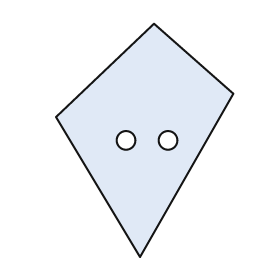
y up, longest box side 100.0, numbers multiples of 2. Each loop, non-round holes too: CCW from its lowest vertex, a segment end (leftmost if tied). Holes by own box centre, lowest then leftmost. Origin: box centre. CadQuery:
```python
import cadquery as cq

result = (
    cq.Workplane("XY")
    .moveTo(-2.0, -50.0)
    .lineTo(38.0, 20.0)
    .lineTo(4.0, 50.0)
    .lineTo(-38.0, 10.0)
    .close()
    .moveTo(-8.0, 0.0)
    .circle(4.0)
    .moveTo(10.0, 0.0)
    .circle(4.0)
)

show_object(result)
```